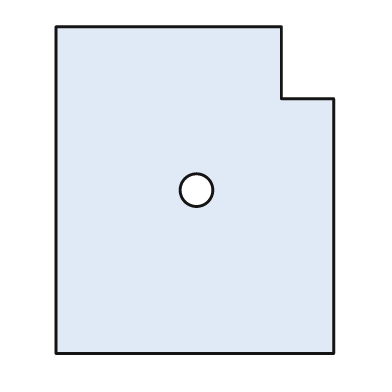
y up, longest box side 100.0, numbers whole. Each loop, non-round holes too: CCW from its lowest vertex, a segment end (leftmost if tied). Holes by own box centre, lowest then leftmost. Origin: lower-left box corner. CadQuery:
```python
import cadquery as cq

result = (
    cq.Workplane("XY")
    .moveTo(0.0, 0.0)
    .lineTo(85.0, 0.0)
    .lineTo(85.0, 78.0)
    .lineTo(69.0, 78.0)
    .lineTo(69.0, 100.0)
    .lineTo(0.0, 100.0)
    .close()
    .moveTo(43.0, 50.0)
    .circle(5.0)
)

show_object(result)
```